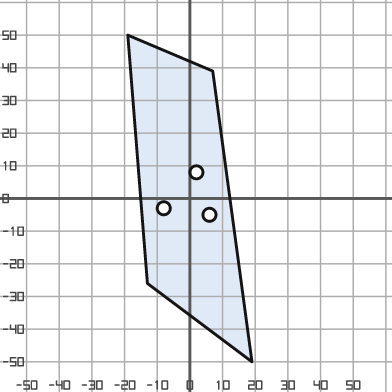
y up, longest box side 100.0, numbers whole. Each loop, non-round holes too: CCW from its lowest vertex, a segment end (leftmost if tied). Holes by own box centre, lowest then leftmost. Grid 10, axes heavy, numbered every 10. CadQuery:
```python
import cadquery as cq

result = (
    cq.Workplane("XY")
    .moveTo(19.0, -50.0)
    .lineTo(7.0, 39.0)
    .lineTo(-19.0, 50.0)
    .lineTo(-13.0, -26.0)
    .close()
    .moveTo(6.0, -5.0)
    .circle(2.0)
    .moveTo(-8.0, -3.0)
    .circle(2.0)
    .moveTo(2.0, 8.0)
    .circle(2.0)
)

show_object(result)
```